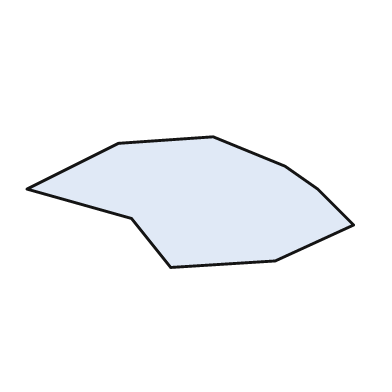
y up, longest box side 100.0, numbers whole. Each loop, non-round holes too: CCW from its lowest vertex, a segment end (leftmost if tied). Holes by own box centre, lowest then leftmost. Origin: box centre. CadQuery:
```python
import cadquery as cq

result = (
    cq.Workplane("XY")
    .moveTo(-6.0, -20.0)
    .lineTo(26.0, -18.0)
    .lineTo(50.0, -7.0)
    .lineTo(39.0, 4.0)
    .lineTo(29.0, 11.0)
    .lineTo(7.0, 20.0)
    .lineTo(-22.0, 18.0)
    .lineTo(-50.0, 4.0)
    .lineTo(-18.0, -5.0)
    .close()
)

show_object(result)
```